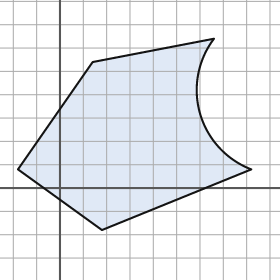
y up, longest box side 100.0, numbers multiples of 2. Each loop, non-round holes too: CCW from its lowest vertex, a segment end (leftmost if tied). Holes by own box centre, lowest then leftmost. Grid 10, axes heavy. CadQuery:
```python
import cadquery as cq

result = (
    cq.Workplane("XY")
    .moveTo(18.0, -18.0)
    .lineTo(82.0, 8.0)
    .threePointArc((60.0, 32.0), (66.0, 64.0))
    .lineTo(14.0, 54.0)
    .lineTo(-18.0, 8.0)
    .close()
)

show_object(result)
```